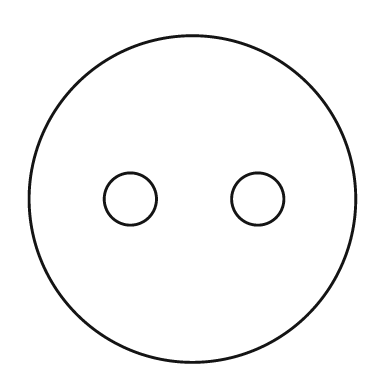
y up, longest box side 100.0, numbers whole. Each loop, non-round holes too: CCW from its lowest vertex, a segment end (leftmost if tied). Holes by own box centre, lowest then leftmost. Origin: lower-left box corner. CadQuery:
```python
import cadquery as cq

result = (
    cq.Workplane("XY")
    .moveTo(50.0, 50.0)
    .circle(50.0)
    .moveTo(31.0, 50.0)
    .circle(8.0)
    .moveTo(70.0, 50.0)
    .circle(8.0)
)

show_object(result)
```